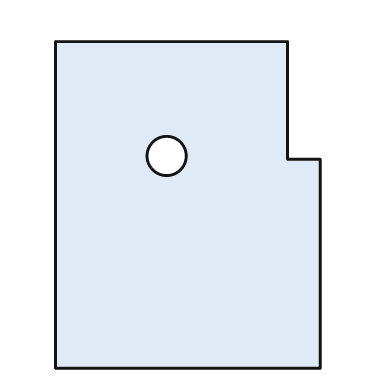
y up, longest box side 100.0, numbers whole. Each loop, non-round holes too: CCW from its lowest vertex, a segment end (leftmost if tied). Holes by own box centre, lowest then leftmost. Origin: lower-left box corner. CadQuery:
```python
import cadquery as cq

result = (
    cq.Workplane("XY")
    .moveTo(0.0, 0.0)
    .lineTo(81.0, 0.0)
    .lineTo(81.0, 64.0)
    .lineTo(71.0, 64.0)
    .lineTo(71.0, 100.0)
    .lineTo(0.0, 100.0)
    .close()
    .moveTo(34.0, 65.0)
    .circle(6.0)
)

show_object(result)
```